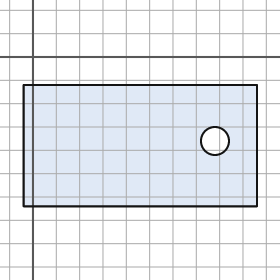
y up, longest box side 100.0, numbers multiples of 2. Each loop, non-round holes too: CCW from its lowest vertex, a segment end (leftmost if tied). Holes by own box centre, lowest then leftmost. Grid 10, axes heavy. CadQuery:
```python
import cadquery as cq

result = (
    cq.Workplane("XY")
    .moveTo(-4.0, -64.0)
    .lineTo(96.0, -64.0)
    .lineTo(96.0, -12.0)
    .lineTo(-4.0, -12.0)
    .close()
    .moveTo(78.0, -36.0)
    .circle(6.0)
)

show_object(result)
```